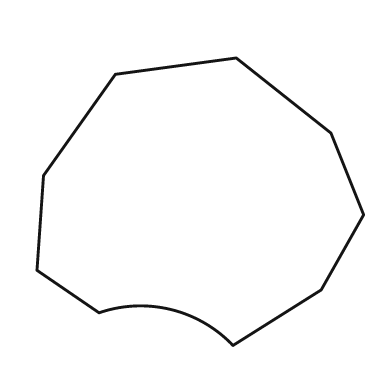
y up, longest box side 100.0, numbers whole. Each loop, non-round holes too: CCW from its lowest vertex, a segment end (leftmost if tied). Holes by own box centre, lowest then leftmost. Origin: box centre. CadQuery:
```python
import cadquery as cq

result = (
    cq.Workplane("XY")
    .moveTo(10.0, -44.0)
    .lineTo(37.0, -27.0)
    .lineTo(50.0, -4.0)
    .lineTo(40.0, 21.0)
    .lineTo(11.0, 44.0)
    .lineTo(-26.0, 39.0)
    .lineTo(-48.0, 8.0)
    .lineTo(-50.0, -21.0)
    .lineTo(-31.0, -34.0)
    .threePointArc((-9.0, -33.0), (10.0, -44.0))
    .close()
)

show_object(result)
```